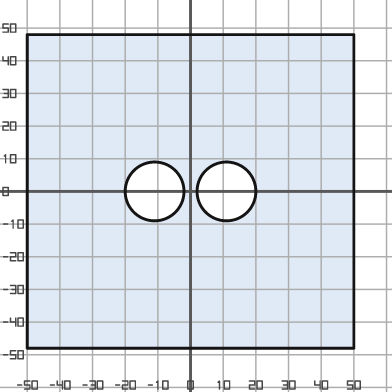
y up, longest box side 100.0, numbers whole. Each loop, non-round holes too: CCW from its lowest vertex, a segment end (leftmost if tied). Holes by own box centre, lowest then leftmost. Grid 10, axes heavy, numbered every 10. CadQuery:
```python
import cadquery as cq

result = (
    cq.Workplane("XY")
    .moveTo(-50.0, -48.0)
    .lineTo(50.0, -48.0)
    .lineTo(50.0, 48.0)
    .lineTo(-50.0, 48.0)
    .close()
    .moveTo(-11.0, 0.0)
    .circle(9.0)
    .moveTo(11.0, 0.0)
    .circle(9.0)
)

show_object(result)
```